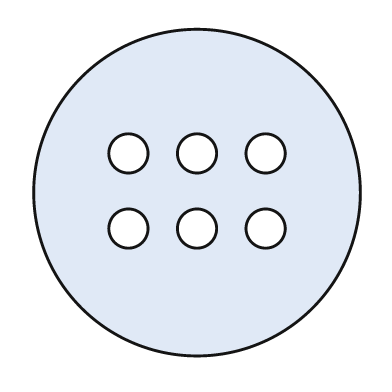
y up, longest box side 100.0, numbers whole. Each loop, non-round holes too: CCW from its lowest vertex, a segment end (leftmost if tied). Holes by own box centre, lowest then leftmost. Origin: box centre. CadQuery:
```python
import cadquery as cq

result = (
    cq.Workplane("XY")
    .moveTo(0.0, 0.0)
    .circle(50.0)
    .moveTo(-21.0, -11.0)
    .circle(6.0)
    .moveTo(0.0, -11.0)
    .circle(6.0)
    .moveTo(21.0, -11.0)
    .circle(6.0)
    .moveTo(-21.0, 12.0)
    .circle(6.0)
    .moveTo(0.0, 12.0)
    .circle(6.0)
    .moveTo(21.0, 12.0)
    .circle(6.0)
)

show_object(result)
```